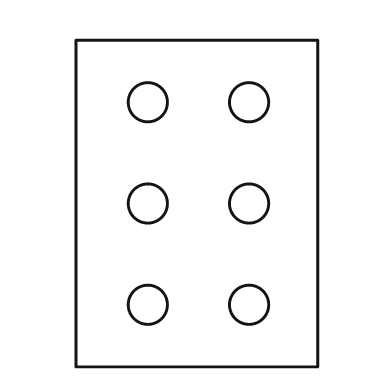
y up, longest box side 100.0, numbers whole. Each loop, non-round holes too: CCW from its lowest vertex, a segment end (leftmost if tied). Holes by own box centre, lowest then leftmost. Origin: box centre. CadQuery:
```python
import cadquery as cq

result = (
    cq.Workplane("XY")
    .moveTo(-37.0, -50.0)
    .lineTo(37.0, -50.0)
    .lineTo(37.0, 50.0)
    .lineTo(-37.0, 50.0)
    .close()
    .moveTo(-15.0, -31.0)
    .circle(6.0)
    .moveTo(16.0, -31.0)
    .circle(6.0)
    .moveTo(-15.0, 0.0)
    .circle(6.0)
    .moveTo(16.0, 0.0)
    .circle(6.0)
    .moveTo(-15.0, 31.0)
    .circle(6.0)
    .moveTo(16.0, 31.0)
    .circle(6.0)
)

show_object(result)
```